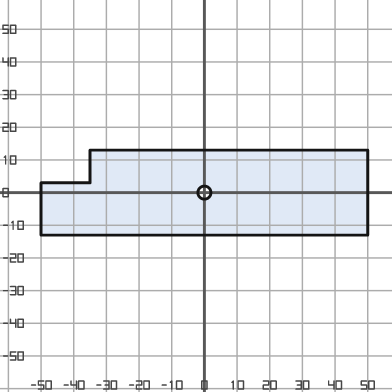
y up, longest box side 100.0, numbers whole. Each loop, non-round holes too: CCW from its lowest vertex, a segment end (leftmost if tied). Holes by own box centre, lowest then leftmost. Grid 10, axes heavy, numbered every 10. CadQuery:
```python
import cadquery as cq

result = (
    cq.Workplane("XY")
    .moveTo(-50.0, -13.0)
    .lineTo(50.0, -13.0)
    .lineTo(50.0, 13.0)
    .lineTo(-35.0, 13.0)
    .lineTo(-35.0, 3.0)
    .lineTo(-50.0, 3.0)
    .close()
    .moveTo(0.0, 0.0)
    .circle(2.0)
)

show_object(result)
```